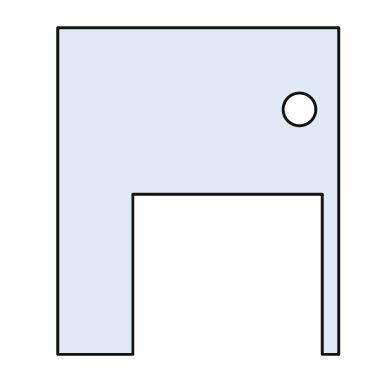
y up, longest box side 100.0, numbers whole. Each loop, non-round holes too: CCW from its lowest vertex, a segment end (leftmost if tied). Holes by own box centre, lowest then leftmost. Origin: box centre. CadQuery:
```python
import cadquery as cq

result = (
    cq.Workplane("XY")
    .moveTo(-43.0, -50.0)
    .lineTo(-20.0, -50.0)
    .lineTo(-20.0, -1.0)
    .lineTo(38.0, -1.0)
    .lineTo(38.0, -50.0)
    .lineTo(43.0, -50.0)
    .lineTo(43.0, 50.0)
    .lineTo(-43.0, 50.0)
    .close()
    .moveTo(31.0, 25.0)
    .circle(5.0)
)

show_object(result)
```